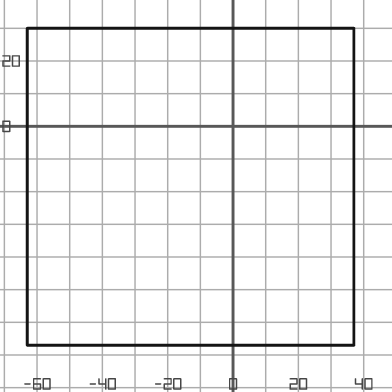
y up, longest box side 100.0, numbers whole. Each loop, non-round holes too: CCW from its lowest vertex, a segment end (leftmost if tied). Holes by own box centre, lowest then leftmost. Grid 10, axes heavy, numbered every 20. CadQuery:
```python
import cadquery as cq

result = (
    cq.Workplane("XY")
    .moveTo(-63.0, -67.0)
    .lineTo(37.0, -67.0)
    .lineTo(37.0, 30.0)
    .lineTo(-63.0, 30.0)
    .close()
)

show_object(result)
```